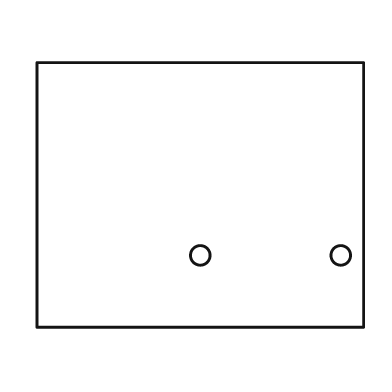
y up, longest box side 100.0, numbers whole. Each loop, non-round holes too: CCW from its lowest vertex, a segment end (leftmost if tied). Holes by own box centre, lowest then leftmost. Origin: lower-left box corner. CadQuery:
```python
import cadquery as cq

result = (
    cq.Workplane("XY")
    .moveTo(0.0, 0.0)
    .lineTo(100.0, 0.0)
    .lineTo(100.0, 81.0)
    .lineTo(0.0, 81.0)
    .close()
    .moveTo(50.0, 22.0)
    .circle(3.0)
    .moveTo(93.0, 22.0)
    .circle(3.0)
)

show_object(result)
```